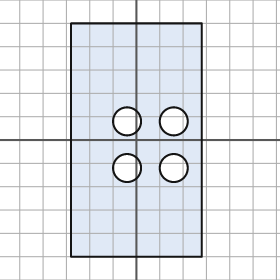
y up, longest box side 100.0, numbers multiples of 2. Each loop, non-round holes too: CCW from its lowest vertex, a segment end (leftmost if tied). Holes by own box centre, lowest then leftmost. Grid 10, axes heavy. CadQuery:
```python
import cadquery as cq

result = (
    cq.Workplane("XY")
    .moveTo(-28.0, -50.0)
    .lineTo(28.0, -50.0)
    .lineTo(28.0, 50.0)
    .lineTo(-28.0, 50.0)
    .close()
    .moveTo(-4.0, -12.0)
    .circle(6.0)
    .moveTo(16.0, -12.0)
    .circle(6.0)
    .moveTo(-4.0, 8.0)
    .circle(6.0)
    .moveTo(16.0, 8.0)
    .circle(6.0)
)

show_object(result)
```